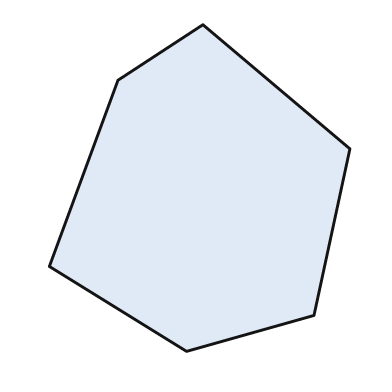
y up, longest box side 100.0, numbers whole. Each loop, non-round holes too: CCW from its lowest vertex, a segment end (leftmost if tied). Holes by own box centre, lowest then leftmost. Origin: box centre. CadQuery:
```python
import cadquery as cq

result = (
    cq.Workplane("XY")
    .moveTo(-4.0, -50.0)
    .lineTo(35.0, -39.0)
    .lineTo(46.0, 12.0)
    .lineTo(1.0, 50.0)
    .lineTo(-25.0, 33.0)
    .lineTo(-46.0, -24.0)
    .close()
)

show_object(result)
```